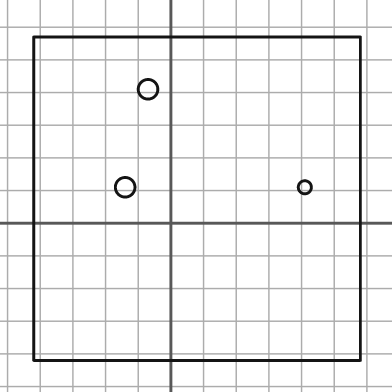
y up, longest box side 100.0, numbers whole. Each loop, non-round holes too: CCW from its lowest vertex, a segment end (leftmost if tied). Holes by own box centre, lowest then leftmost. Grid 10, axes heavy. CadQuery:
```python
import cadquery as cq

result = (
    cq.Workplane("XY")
    .moveTo(-42.0, -42.0)
    .lineTo(58.0, -42.0)
    .lineTo(58.0, 57.0)
    .lineTo(-42.0, 57.0)
    .close()
    .moveTo(-14.0, 11.0)
    .circle(3.0)
    .moveTo(41.0, 11.0)
    .circle(2.0)
    .moveTo(-7.0, 41.0)
    .circle(3.0)
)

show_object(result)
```